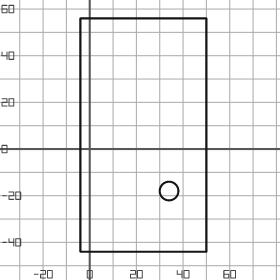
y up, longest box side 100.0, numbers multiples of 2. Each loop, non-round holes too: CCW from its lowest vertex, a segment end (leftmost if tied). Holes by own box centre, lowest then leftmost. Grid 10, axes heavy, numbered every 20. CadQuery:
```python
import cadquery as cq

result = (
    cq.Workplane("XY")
    .moveTo(-4.0, -44.0)
    .lineTo(50.0, -44.0)
    .lineTo(50.0, 56.0)
    .lineTo(-4.0, 56.0)
    .close()
    .moveTo(34.0, -18.0)
    .circle(4.0)
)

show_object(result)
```